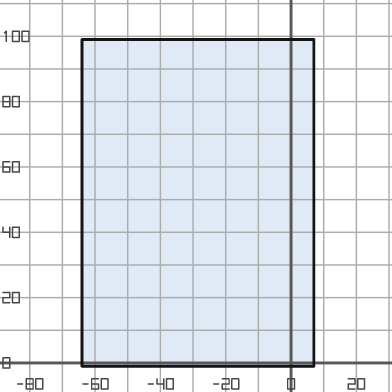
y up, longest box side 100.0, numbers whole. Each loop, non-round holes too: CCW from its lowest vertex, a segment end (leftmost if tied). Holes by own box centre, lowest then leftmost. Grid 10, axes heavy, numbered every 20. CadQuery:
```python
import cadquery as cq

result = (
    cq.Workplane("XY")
    .moveTo(-64.0, -1.0)
    .lineTo(7.0, -1.0)
    .lineTo(7.0, 99.0)
    .lineTo(-64.0, 99.0)
    .close()
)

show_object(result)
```